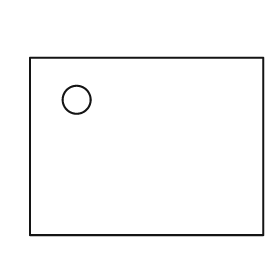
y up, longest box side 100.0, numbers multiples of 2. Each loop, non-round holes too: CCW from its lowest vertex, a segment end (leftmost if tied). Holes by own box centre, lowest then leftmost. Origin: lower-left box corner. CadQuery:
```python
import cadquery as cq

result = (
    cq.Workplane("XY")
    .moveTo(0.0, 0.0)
    .lineTo(100.0, 0.0)
    .lineTo(100.0, 76.0)
    .lineTo(0.0, 76.0)
    .close()
    .moveTo(20.0, 58.0)
    .circle(6.0)
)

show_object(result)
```